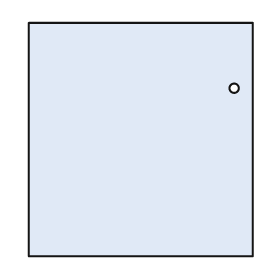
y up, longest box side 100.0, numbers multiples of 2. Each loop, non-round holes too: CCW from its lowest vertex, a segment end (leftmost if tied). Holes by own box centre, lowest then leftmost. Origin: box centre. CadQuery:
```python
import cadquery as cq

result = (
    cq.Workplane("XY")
    .moveTo(-48.0, -50.0)
    .lineTo(48.0, -50.0)
    .lineTo(48.0, 50.0)
    .lineTo(-48.0, 50.0)
    .close()
    .moveTo(40.0, 22.0)
    .circle(2.0)
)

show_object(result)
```